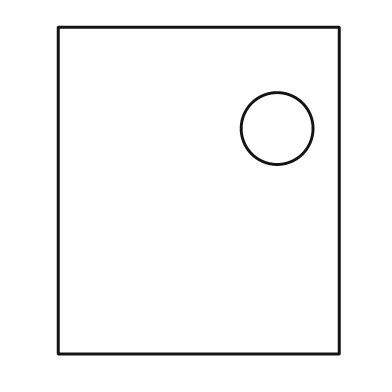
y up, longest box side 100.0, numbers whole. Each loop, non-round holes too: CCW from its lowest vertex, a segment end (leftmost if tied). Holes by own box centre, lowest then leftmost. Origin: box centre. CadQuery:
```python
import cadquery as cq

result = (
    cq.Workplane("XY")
    .moveTo(-43.0, -50.0)
    .lineTo(43.0, -50.0)
    .lineTo(43.0, 50.0)
    .lineTo(-43.0, 50.0)
    .close()
    .moveTo(24.0, 19.0)
    .circle(11.0)
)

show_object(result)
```